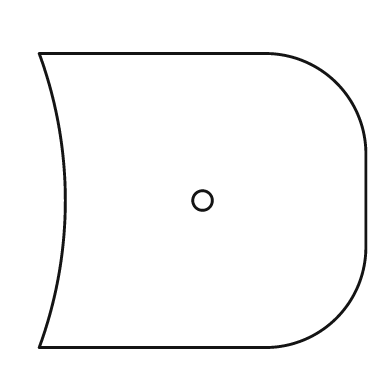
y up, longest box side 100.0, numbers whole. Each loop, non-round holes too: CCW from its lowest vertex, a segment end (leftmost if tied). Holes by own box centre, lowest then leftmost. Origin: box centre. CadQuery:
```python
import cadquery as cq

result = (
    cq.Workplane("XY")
    .moveTo(-50.0, -45.0)
    .lineTo(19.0, -45.0)
    .threePointArc((41.0, -36.0), (50.0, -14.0))
    .lineTo(50.0, 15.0)
    .threePointArc((41.0, 36.0), (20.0, 45.0))
    .lineTo(-50.0, 45.0)
    .threePointArc((-42.0, 0.0), (-50.0, -45.0))
    .close()
    .moveTo(0.0, 0.0)
    .circle(3.0)
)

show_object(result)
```